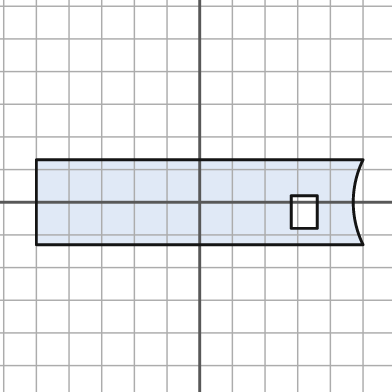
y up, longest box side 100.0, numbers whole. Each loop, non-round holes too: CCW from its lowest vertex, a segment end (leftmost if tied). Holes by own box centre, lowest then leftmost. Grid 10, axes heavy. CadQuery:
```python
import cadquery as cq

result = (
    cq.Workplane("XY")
    .moveTo(-50.0, -13.0)
    .lineTo(50.0, -13.0)
    .threePointArc((47.0, 0.0), (50.0, 13.0))
    .lineTo(-50.0, 13.0)
    .close()
    .moveTo(28.0, -8.0)
    .lineTo(36.0, -8.0)
    .lineTo(36.0, 2.0)
    .lineTo(28.0, 2.0)
    .close()
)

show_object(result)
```